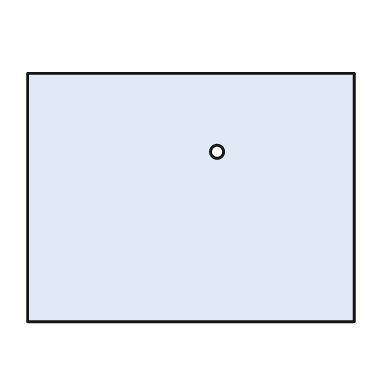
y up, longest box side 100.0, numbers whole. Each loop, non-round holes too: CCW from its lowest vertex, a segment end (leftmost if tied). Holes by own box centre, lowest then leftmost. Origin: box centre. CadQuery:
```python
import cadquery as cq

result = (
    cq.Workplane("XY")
    .moveTo(-50.0, -38.0)
    .lineTo(50.0, -38.0)
    .lineTo(50.0, 38.0)
    .lineTo(-50.0, 38.0)
    .close()
    .moveTo(8.0, 14.0)
    .circle(2.0)
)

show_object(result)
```